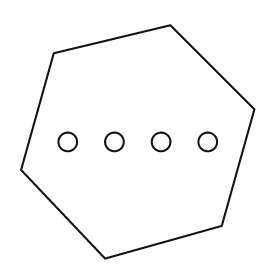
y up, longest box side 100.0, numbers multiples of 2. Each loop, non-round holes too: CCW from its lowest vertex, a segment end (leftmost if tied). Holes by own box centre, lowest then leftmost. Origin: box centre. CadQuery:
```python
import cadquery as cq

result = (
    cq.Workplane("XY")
    .moveTo(-14.0, -50.0)
    .lineTo(36.0, -36.0)
    .lineTo(50.0, 14.0)
    .lineTo(14.0, 50.0)
    .lineTo(-36.0, 38.0)
    .lineTo(-50.0, -12.0)
    .close()
    .moveTo(-30.0, 0.0)
    .circle(4.0)
    .moveTo(-10.0, 0.0)
    .circle(4.0)
    .moveTo(10.0, 0.0)
    .circle(4.0)
    .moveTo(30.0, 0.0)
    .circle(4.0)
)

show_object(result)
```